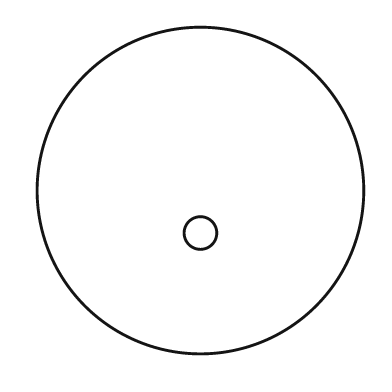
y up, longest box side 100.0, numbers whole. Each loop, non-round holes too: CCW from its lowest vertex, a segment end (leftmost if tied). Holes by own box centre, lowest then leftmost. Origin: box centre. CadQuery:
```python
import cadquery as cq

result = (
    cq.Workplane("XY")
    .moveTo(0.0, 0.0)
    .circle(50.0)
    .moveTo(0.0, -13.0)
    .circle(5.0)
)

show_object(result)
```